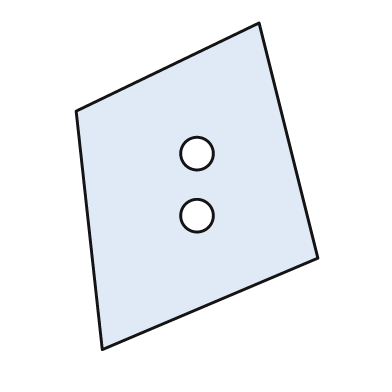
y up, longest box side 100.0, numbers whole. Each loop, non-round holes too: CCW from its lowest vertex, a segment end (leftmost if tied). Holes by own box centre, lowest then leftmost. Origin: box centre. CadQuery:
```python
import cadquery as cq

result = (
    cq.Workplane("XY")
    .moveTo(-29.0, -50.0)
    .lineTo(37.0, -22.0)
    .lineTo(19.0, 50.0)
    .lineTo(-37.0, 23.0)
    .close()
    .moveTo(0.0, -9.0)
    .circle(5.0)
    .moveTo(0.0, 10.0)
    .circle(5.0)
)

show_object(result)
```